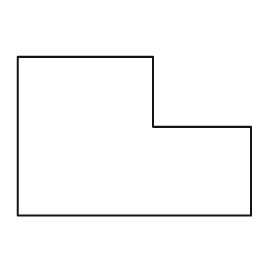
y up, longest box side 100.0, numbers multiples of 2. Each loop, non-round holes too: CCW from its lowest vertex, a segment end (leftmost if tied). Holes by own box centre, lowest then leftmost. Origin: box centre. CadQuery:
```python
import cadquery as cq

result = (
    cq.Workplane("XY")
    .moveTo(-50.0, -34.0)
    .lineTo(50.0, -34.0)
    .lineTo(50.0, 4.0)
    .lineTo(8.0, 4.0)
    .lineTo(8.0, 34.0)
    .lineTo(-50.0, 34.0)
    .close()
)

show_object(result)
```